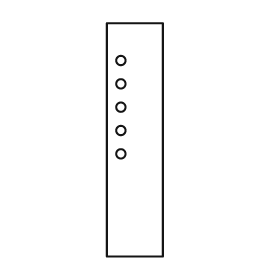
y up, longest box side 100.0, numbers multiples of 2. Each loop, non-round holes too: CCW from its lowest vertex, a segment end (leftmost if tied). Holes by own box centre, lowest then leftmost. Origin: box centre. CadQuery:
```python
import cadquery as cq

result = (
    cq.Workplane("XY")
    .moveTo(-12.0, -50.0)
    .lineTo(12.0, -50.0)
    .lineTo(12.0, 50.0)
    .lineTo(-12.0, 50.0)
    .close()
    .moveTo(-6.0, -6.0)
    .circle(2.0)
    .moveTo(-6.0, 4.0)
    .circle(2.0)
    .moveTo(-6.0, 14.0)
    .circle(2.0)
    .moveTo(-6.0, 24.0)
    .circle(2.0)
    .moveTo(-6.0, 34.0)
    .circle(2.0)
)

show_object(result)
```